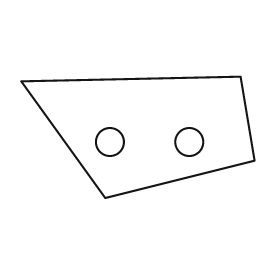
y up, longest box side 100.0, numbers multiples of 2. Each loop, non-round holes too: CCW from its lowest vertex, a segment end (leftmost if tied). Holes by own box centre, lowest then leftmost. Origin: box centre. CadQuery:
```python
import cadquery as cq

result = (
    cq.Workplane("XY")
    .moveTo(-14.0, -26.0)
    .lineTo(50.0, -10.0)
    .lineTo(44.0, 26.0)
    .lineTo(-50.0, 24.0)
    .close()
    .moveTo(-12.0, -2.0)
    .circle(6.0)
    .moveTo(22.0, -2.0)
    .circle(6.0)
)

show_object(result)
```